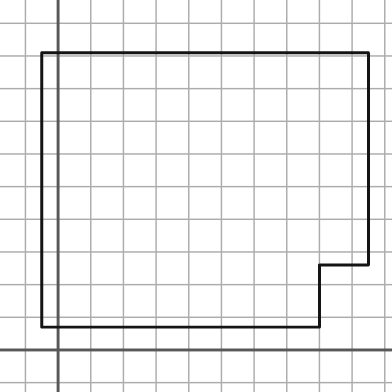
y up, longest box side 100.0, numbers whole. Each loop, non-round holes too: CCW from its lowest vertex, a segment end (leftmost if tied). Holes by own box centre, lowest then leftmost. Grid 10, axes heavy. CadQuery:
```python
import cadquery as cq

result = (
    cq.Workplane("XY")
    .moveTo(-5.0, 7.0)
    .lineTo(80.0, 7.0)
    .lineTo(80.0, 26.0)
    .lineTo(95.0, 26.0)
    .lineTo(95.0, 91.0)
    .lineTo(-5.0, 91.0)
    .close()
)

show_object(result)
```